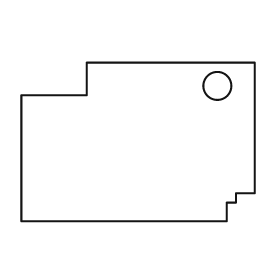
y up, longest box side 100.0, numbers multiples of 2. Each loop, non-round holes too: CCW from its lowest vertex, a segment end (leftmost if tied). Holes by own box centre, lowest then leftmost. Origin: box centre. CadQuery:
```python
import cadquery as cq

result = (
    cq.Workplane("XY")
    .moveTo(-50.0, -34.0)
    .lineTo(38.0, -34.0)
    .lineTo(38.0, -26.0)
    .lineTo(42.0, -26.0)
    .lineTo(42.0, -22.0)
    .lineTo(50.0, -22.0)
    .lineTo(50.0, 34.0)
    .lineTo(-22.0, 34.0)
    .lineTo(-22.0, 20.0)
    .lineTo(-50.0, 20.0)
    .close()
    .moveTo(34.0, 24.0)
    .circle(6.0)
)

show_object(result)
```